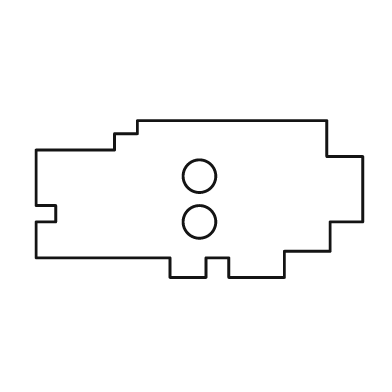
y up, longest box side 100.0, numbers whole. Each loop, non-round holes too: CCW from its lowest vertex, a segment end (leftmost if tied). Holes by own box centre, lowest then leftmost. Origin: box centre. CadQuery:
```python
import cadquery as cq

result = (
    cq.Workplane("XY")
    .moveTo(-9.0, -24.0)
    .lineTo(2.0, -24.0)
    .lineTo(2.0, -18.0)
    .lineTo(9.0, -18.0)
    .lineTo(9.0, -24.0)
    .lineTo(26.0, -24.0)
    .lineTo(26.0, -16.0)
    .lineTo(40.0, -16.0)
    .lineTo(40.0, -7.0)
    .lineTo(50.0, -7.0)
    .lineTo(50.0, 13.0)
    .lineTo(39.0, 13.0)
    .lineTo(39.0, 24.0)
    .lineTo(-19.0, 24.0)
    .lineTo(-19.0, 20.0)
    .lineTo(-26.0, 20.0)
    .lineTo(-26.0, 15.0)
    .lineTo(-50.0, 15.0)
    .lineTo(-50.0, -2.0)
    .lineTo(-44.0, -2.0)
    .lineTo(-44.0, -7.0)
    .lineTo(-50.0, -7.0)
    .lineTo(-50.0, -18.0)
    .lineTo(-9.0, -18.0)
    .close()
    .moveTo(0.0, -7.0)
    .circle(5.0)
    .moveTo(0.0, 7.0)
    .circle(5.0)
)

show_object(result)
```